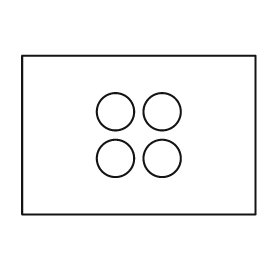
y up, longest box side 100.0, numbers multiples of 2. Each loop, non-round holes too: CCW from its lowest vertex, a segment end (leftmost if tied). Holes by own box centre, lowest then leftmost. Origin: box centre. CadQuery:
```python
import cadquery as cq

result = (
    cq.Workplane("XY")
    .moveTo(-50.0, -34.0)
    .lineTo(50.0, -34.0)
    .lineTo(50.0, 34.0)
    .lineTo(-50.0, 34.0)
    .close()
    .moveTo(-10.0, -10.0)
    .circle(8.0)
    .moveTo(10.0, -10.0)
    .circle(8.0)
    .moveTo(-10.0, 10.0)
    .circle(8.0)
    .moveTo(10.0, 10.0)
    .circle(8.0)
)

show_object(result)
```